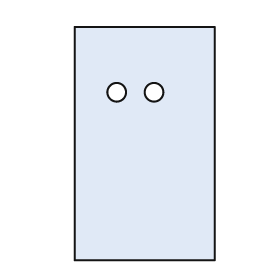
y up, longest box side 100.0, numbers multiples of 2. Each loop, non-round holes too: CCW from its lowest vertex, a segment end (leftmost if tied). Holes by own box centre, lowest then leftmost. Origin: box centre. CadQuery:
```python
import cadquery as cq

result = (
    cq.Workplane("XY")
    .moveTo(-30.0, -50.0)
    .lineTo(30.0, -50.0)
    .lineTo(30.0, 50.0)
    .lineTo(-30.0, 50.0)
    .close()
    .moveTo(-12.0, 22.0)
    .circle(4.0)
    .moveTo(4.0, 22.0)
    .circle(4.0)
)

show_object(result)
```